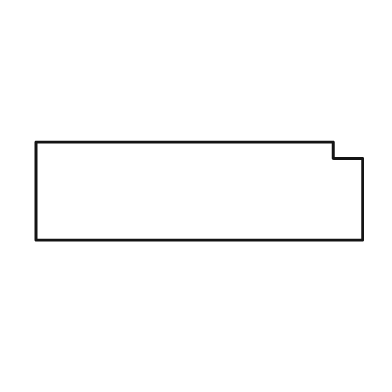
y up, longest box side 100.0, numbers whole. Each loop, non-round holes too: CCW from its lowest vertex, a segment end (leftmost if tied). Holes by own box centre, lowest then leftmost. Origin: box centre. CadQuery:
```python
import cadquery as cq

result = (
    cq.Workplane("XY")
    .moveTo(-50.0, -15.0)
    .lineTo(50.0, -15.0)
    .lineTo(50.0, 10.0)
    .lineTo(41.0, 10.0)
    .lineTo(41.0, 15.0)
    .lineTo(-50.0, 15.0)
    .close()
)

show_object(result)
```